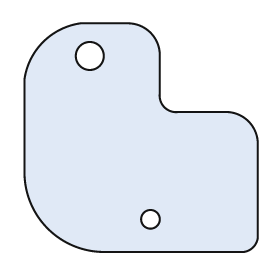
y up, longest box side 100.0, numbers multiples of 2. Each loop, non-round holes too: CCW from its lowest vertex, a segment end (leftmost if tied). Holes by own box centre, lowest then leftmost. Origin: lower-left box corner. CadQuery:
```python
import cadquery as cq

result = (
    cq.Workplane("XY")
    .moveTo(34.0, 0.0)
    .lineTo(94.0, 0.0)
    .threePointArc((98.0, 2.0), (100.0, 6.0))
    .lineTo(100.0, 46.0)
    .threePointArc((96.0, 56.0), (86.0, 60.0))
    .lineTo(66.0, 60.0)
    .threePointArc((60.0, 62.0), (58.0, 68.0))
    .lineTo(58.0, 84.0)
    .threePointArc((54.0, 94.0), (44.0, 98.0))
    .lineTo(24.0, 98.0)
    .threePointArc((8.0, 90.0), (0.0, 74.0))
    .lineTo(0.0, 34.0)
    .threePointArc((10.0, 10.0), (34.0, 0.0))
    .close()
    .moveTo(54.0, 14.0)
    .circle(4.0)
    .moveTo(28.0, 84.0)
    .circle(6.0)
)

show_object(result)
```